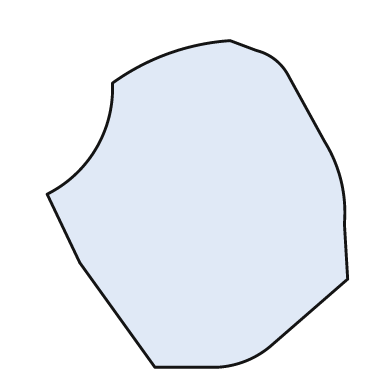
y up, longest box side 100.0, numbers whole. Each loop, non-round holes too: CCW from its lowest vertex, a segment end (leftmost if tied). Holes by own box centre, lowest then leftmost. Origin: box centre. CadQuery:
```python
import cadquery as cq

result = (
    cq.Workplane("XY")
    .moveTo(-13.0, -50.0)
    .lineTo(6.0, -50.0)
    .threePointArc((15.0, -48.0), (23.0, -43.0))
    .lineTo(46.0, -23.0)
    .lineTo(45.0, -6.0)
    .threePointArc((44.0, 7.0), (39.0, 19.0))
    .lineTo(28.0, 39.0)
    .threePointArc((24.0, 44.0), (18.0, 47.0))
    .lineTo(10.0, 50.0)
    .threePointArc((-9.0, 46.0), (-26.0, 37.0))
    .threePointArc((-31.0, 17.0), (-46.0, 3.0))
    .lineTo(-36.0, -18.0)
    .close()
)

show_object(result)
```